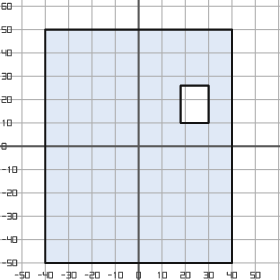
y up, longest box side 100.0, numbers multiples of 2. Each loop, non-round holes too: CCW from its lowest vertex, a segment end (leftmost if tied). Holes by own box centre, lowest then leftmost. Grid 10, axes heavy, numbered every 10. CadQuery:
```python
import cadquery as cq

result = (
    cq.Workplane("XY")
    .moveTo(-40.0, -50.0)
    .lineTo(40.0, -50.0)
    .lineTo(40.0, 50.0)
    .lineTo(-40.0, 50.0)
    .close()
    .moveTo(18.0, 10.0)
    .lineTo(30.0, 10.0)
    .lineTo(30.0, 26.0)
    .lineTo(18.0, 26.0)
    .close()
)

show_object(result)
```